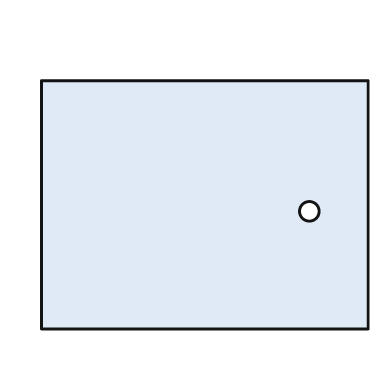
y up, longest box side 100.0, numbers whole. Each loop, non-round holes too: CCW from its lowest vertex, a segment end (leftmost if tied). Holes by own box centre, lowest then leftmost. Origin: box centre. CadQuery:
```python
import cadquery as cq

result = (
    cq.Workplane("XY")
    .moveTo(-50.0, -38.0)
    .lineTo(50.0, -38.0)
    .lineTo(50.0, 38.0)
    .lineTo(-50.0, 38.0)
    .close()
    .moveTo(32.0, -2.0)
    .circle(3.0)
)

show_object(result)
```